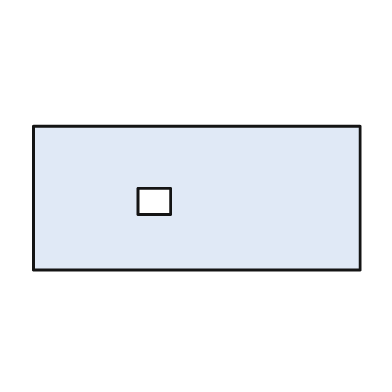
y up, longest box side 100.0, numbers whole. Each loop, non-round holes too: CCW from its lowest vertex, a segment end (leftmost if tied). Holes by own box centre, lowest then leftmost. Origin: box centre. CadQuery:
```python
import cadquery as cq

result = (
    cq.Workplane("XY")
    .moveTo(-50.0, -22.0)
    .lineTo(50.0, -22.0)
    .lineTo(50.0, 22.0)
    .lineTo(-50.0, 22.0)
    .close()
    .moveTo(-18.0, -5.0)
    .lineTo(-8.0, -5.0)
    .lineTo(-8.0, 3.0)
    .lineTo(-18.0, 3.0)
    .close()
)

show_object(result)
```